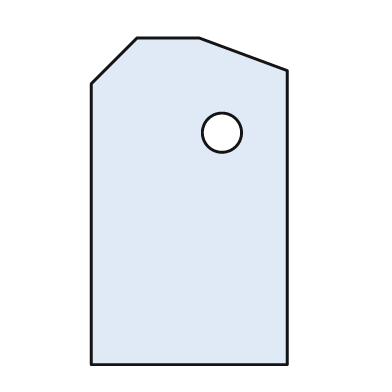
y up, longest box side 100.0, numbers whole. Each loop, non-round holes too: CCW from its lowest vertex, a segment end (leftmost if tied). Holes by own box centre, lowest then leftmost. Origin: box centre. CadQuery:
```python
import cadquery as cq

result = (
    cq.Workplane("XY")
    .moveTo(-30.0, -50.0)
    .lineTo(30.0, -50.0)
    .lineTo(30.0, 40.0)
    .lineTo(3.0, 50.0)
    .lineTo(-16.0, 50.0)
    .lineTo(-30.0, 36.0)
    .close()
    .moveTo(10.0, 21.0)
    .circle(6.0)
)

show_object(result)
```